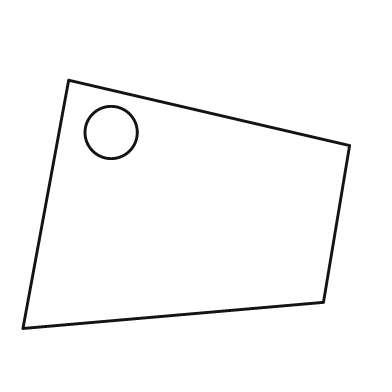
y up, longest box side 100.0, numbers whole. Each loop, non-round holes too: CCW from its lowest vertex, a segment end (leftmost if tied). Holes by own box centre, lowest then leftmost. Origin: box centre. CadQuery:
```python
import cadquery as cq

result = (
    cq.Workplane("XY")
    .moveTo(-50.0, -38.0)
    .lineTo(42.0, -30.0)
    .lineTo(50.0, 18.0)
    .lineTo(-36.0, 38.0)
    .close()
    .moveTo(-23.0, 22.0)
    .circle(8.0)
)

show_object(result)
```